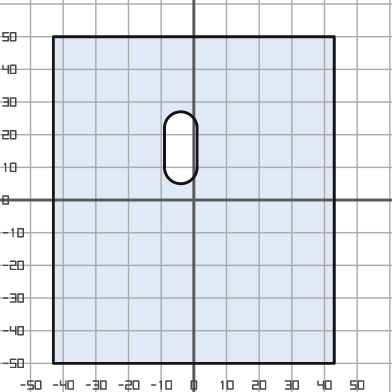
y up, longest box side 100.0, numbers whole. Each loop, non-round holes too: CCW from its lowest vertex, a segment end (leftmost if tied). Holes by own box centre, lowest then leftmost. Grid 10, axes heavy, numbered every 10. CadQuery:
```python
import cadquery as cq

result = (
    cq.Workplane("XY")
    .moveTo(-43.0, -50.0)
    .lineTo(43.0, -50.0)
    .lineTo(43.0, 50.0)
    .lineTo(-43.0, 50.0)
    .close()
    .moveTo(-9.0, 10.0)
    .threePointArc((-4.0, 5.0), (1.0, 10.0))
    .lineTo(1.0, 22.0)
    .threePointArc((-4.0, 27.0), (-9.0, 22.0))
    .close()
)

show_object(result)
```